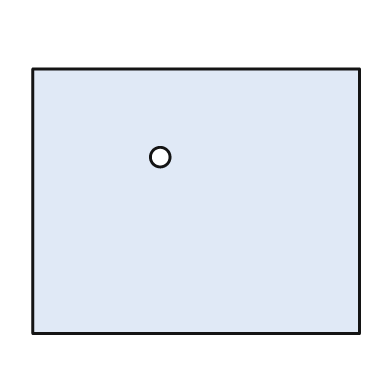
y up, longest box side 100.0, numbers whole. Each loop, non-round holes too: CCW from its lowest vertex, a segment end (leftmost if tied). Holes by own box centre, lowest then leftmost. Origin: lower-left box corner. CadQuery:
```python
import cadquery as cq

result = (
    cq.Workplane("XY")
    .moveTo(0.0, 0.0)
    .lineTo(100.0, 0.0)
    .lineTo(100.0, 81.0)
    .lineTo(0.0, 81.0)
    .close()
    .moveTo(39.0, 54.0)
    .circle(3.0)
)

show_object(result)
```